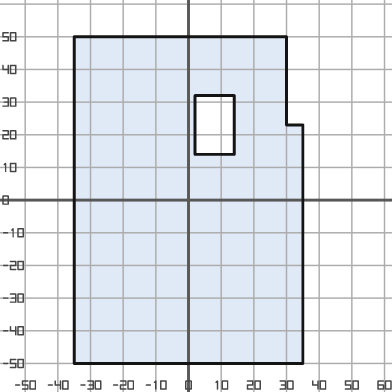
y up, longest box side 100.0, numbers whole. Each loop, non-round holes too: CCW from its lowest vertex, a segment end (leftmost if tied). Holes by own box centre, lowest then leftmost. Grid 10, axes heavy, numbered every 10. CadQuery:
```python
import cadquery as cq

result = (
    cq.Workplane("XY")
    .moveTo(-35.0, -50.0)
    .lineTo(35.0, -50.0)
    .lineTo(35.0, 23.0)
    .lineTo(30.0, 23.0)
    .lineTo(30.0, 50.0)
    .lineTo(-35.0, 50.0)
    .close()
    .moveTo(2.0, 14.0)
    .lineTo(14.0, 14.0)
    .lineTo(14.0, 32.0)
    .lineTo(2.0, 32.0)
    .close()
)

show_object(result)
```